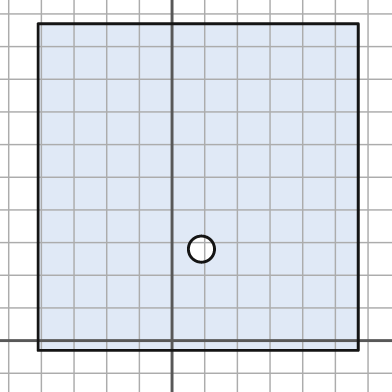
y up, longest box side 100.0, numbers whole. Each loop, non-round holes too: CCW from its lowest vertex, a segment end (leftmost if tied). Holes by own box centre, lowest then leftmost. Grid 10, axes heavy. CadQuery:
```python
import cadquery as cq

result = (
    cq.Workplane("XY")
    .moveTo(-41.0, -3.0)
    .lineTo(57.0, -3.0)
    .lineTo(57.0, 97.0)
    .lineTo(-41.0, 97.0)
    .close()
    .moveTo(9.0, 28.0)
    .circle(4.0)
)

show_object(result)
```